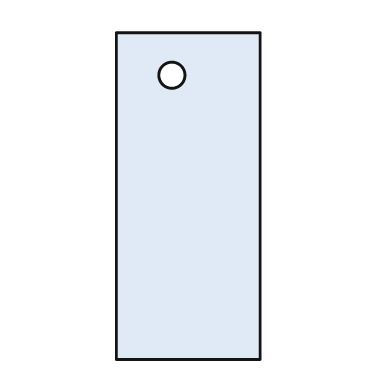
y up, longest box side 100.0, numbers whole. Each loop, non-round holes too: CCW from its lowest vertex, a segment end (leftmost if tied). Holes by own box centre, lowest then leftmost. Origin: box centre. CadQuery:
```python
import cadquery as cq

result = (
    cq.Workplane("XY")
    .moveTo(-22.0, -50.0)
    .lineTo(22.0, -50.0)
    .lineTo(22.0, 50.0)
    .lineTo(-22.0, 50.0)
    .close()
    .moveTo(-5.0, 37.0)
    .circle(4.0)
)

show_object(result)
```